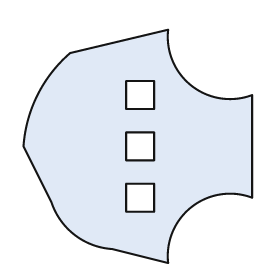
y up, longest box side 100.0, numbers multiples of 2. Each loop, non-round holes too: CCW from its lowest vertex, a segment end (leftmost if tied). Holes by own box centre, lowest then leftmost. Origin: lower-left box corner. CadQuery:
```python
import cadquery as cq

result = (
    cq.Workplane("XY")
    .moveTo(62.0, 0.0)
    .threePointArc((72.0, 24.0), (98.0, 28.0))
    .lineTo(98.0, 72.0)
    .threePointArc((72.0, 76.0), (62.0, 100.0))
    .lineTo(20.0, 90.0)
    .threePointArc((6.0, 72.0), (0.0, 50.0))
    .lineTo(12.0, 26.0)
    .threePointArc((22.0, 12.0), (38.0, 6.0))
    .close()
    .moveTo(44.0, 22.0)
    .lineTo(56.0, 22.0)
    .lineTo(56.0, 34.0)
    .lineTo(44.0, 34.0)
    .close()
    .moveTo(44.0, 44.0)
    .lineTo(56.0, 44.0)
    .lineTo(56.0, 56.0)
    .lineTo(44.0, 56.0)
    .close()
    .moveTo(44.0, 66.0)
    .lineTo(56.0, 66.0)
    .lineTo(56.0, 78.0)
    .lineTo(44.0, 78.0)
    .close()
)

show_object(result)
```